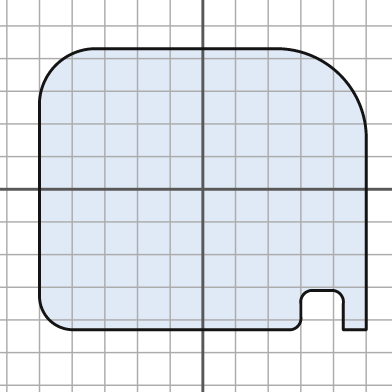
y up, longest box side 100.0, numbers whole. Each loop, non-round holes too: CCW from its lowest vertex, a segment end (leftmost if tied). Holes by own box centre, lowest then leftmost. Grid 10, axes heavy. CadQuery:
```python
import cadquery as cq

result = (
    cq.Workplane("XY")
    .moveTo(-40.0, -43.0)
    .lineTo(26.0, -43.0)
    .threePointArc((29.0, -42.0), (30.0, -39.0))
    .lineTo(30.0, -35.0)
    .threePointArc((31.0, -32.0), (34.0, -31.0))
    .lineTo(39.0, -31.0)
    .threePointArc((42.0, -32.0), (43.0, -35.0))
    .lineTo(43.0, -43.0)
    .lineTo(50.0, -43.0)
    .lineTo(50.0, 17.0)
    .threePointArc((42.0, 35.0), (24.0, 43.0))
    .lineTo(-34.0, 43.0)
    .threePointArc((-45.0, 38.0), (-50.0, 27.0))
    .lineTo(-50.0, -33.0)
    .threePointArc((-47.0, -40.0), (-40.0, -43.0))
    .close()
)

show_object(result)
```